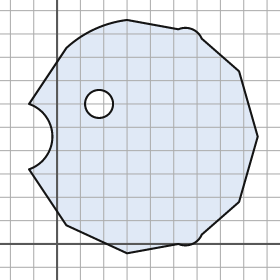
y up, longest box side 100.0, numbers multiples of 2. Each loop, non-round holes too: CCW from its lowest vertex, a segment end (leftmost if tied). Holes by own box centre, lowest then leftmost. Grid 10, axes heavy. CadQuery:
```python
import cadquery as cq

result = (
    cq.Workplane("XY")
    .moveTo(30.0, -4.0)
    .lineTo(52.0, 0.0)
    .threePointArc((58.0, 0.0), (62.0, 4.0))
    .lineTo(78.0, 18.0)
    .lineTo(86.0, 46.0)
    .lineTo(78.0, 74.0)
    .lineTo(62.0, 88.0)
    .threePointArc((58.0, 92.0), (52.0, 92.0))
    .lineTo(30.0, 96.0)
    .threePointArc((16.0, 92.0), (4.0, 84.0))
    .lineTo(-12.0, 60.0)
    .threePointArc((-2.0, 46.0), (-12.0, 32.0))
    .lineTo(4.0, 8.0)
    .close()
    .moveTo(18.0, 60.0)
    .circle(6.0)
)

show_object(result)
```